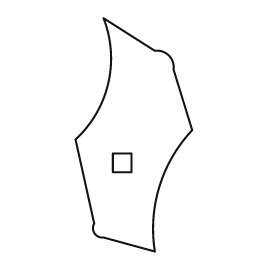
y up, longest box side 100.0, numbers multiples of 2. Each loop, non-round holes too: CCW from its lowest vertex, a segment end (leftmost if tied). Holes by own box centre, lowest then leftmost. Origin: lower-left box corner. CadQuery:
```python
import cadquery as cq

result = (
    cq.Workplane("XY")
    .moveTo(34.0, 0.0)
    .threePointArc((36.0, 28.0), (50.0, 52.0))
    .lineTo(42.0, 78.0)
    .threePointArc((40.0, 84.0), (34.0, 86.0))
    .lineTo(12.0, 100.0)
    .threePointArc((14.0, 72.0), (0.0, 48.0))
    .lineTo(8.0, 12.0)
    .threePointArc((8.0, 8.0), (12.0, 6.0))
    .close()
    .moveTo(16.0, 34.0)
    .lineTo(24.0, 34.0)
    .lineTo(24.0, 42.0)
    .lineTo(16.0, 42.0)
    .close()
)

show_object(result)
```